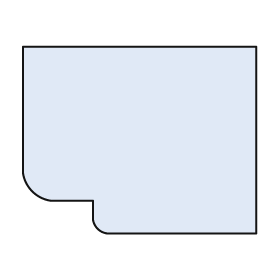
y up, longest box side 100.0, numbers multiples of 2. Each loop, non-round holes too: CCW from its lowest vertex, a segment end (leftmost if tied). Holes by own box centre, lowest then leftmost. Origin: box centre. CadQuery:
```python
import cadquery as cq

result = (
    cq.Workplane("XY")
    .moveTo(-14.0, -40.0)
    .lineTo(50.0, -40.0)
    .lineTo(50.0, 40.0)
    .lineTo(-50.0, 40.0)
    .lineTo(-50.0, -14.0)
    .threePointArc((-46.0, -22.0), (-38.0, -26.0))
    .lineTo(-20.0, -26.0)
    .lineTo(-20.0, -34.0)
    .threePointArc((-18.0, -38.0), (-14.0, -40.0))
    .close()
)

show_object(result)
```